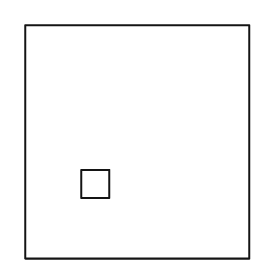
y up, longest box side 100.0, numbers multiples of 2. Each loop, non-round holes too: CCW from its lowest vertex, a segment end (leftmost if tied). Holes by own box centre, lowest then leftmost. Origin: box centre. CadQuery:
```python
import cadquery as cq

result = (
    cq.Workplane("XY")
    .moveTo(-48.0, -50.0)
    .lineTo(48.0, -50.0)
    .lineTo(48.0, 50.0)
    .lineTo(-48.0, 50.0)
    .close()
    .moveTo(-24.0, -24.0)
    .lineTo(-12.0, -24.0)
    .lineTo(-12.0, -12.0)
    .lineTo(-24.0, -12.0)
    .close()
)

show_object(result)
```